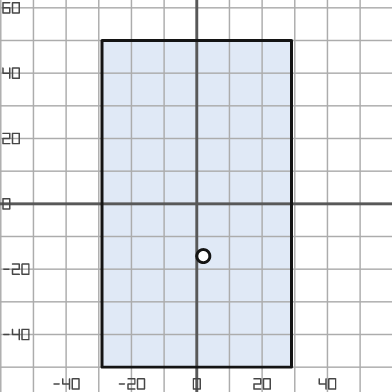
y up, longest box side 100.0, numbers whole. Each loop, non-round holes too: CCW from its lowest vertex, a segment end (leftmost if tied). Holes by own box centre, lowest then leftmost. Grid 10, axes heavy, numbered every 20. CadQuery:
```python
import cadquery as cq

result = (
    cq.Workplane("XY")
    .moveTo(-29.0, -50.0)
    .lineTo(29.0, -50.0)
    .lineTo(29.0, 50.0)
    .lineTo(-29.0, 50.0)
    .close()
    .moveTo(2.0, -16.0)
    .circle(2.0)
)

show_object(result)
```